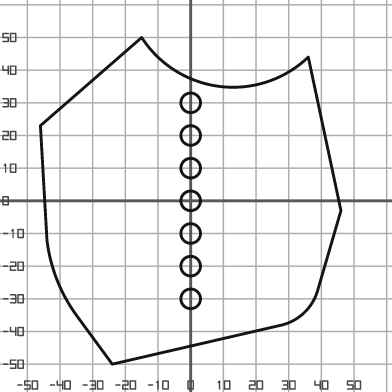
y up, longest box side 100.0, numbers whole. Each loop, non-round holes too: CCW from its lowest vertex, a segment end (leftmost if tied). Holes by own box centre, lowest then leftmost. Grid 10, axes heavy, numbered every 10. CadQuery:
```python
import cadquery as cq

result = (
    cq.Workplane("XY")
    .moveTo(-24.0, -50.0)
    .lineTo(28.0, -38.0)
    .threePointArc((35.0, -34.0), (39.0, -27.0))
    .lineTo(46.0, -3.0)
    .lineTo(36.0, 44.0)
    .threePointArc((9.0, 35.0), (-15.0, 50.0))
    .lineTo(-46.0, 23.0)
    .lineTo(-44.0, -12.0)
    .threePointArc((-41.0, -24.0), (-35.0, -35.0))
    .close()
    .moveTo(0.0, -30.0)
    .circle(3.0)
    .moveTo(0.0, -20.0)
    .circle(3.0)
    .moveTo(0.0, -10.0)
    .circle(3.0)
    .moveTo(0.0, 0.0)
    .circle(3.0)
    .moveTo(0.0, 10.0)
    .circle(3.0)
    .moveTo(0.0, 20.0)
    .circle(3.0)
    .moveTo(0.0, 30.0)
    .circle(3.0)
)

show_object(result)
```